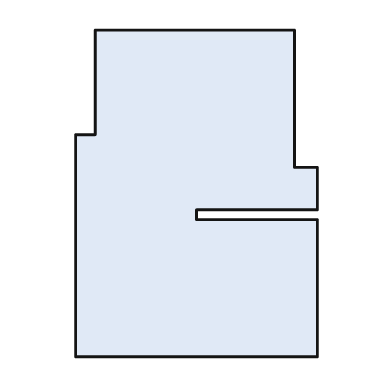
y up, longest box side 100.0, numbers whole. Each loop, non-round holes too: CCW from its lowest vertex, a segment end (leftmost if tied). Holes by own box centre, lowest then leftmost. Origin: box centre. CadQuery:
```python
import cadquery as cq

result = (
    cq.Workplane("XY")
    .moveTo(-37.0, -50.0)
    .lineTo(37.0, -50.0)
    .lineTo(37.0, -8.0)
    .lineTo(0.0, -8.0)
    .lineTo(0.0, -5.0)
    .lineTo(37.0, -5.0)
    .lineTo(37.0, 8.0)
    .lineTo(30.0, 8.0)
    .lineTo(30.0, 50.0)
    .lineTo(-31.0, 50.0)
    .lineTo(-31.0, 18.0)
    .lineTo(-37.0, 18.0)
    .close()
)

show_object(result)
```